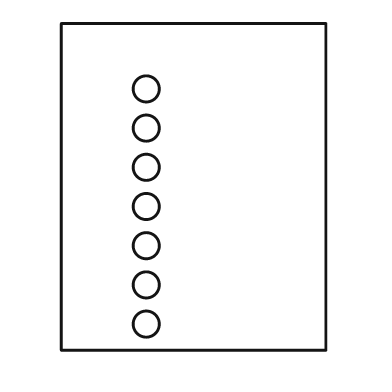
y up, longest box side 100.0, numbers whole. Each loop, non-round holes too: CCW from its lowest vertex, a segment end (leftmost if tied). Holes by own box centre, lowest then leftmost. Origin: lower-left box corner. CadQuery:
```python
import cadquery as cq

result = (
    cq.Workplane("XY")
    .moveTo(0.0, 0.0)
    .lineTo(81.0, 0.0)
    .lineTo(81.0, 100.0)
    .lineTo(0.0, 100.0)
    .close()
    .moveTo(26.0, 8.0)
    .circle(4.0)
    .moveTo(26.0, 20.0)
    .circle(4.0)
    .moveTo(26.0, 32.0)
    .circle(4.0)
    .moveTo(26.0, 44.0)
    .circle(4.0)
    .moveTo(26.0, 56.0)
    .circle(4.0)
    .moveTo(26.0, 68.0)
    .circle(4.0)
    .moveTo(26.0, 80.0)
    .circle(4.0)
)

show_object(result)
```